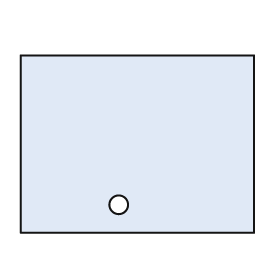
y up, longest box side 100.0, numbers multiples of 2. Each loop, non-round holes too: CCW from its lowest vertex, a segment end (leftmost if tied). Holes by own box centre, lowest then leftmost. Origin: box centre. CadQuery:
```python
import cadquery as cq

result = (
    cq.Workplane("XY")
    .moveTo(-50.0, -38.0)
    .lineTo(50.0, -38.0)
    .lineTo(50.0, 38.0)
    .lineTo(-50.0, 38.0)
    .close()
    .moveTo(-8.0, -26.0)
    .circle(4.0)
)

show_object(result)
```